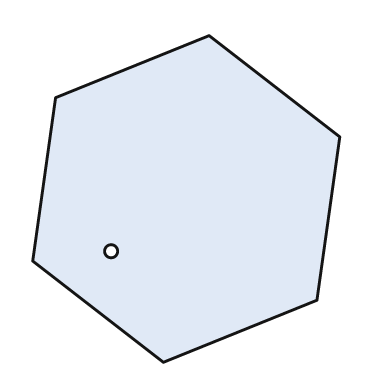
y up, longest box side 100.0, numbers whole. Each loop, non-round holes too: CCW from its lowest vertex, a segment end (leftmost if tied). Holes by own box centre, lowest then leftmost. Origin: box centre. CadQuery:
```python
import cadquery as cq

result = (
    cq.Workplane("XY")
    .moveTo(-7.0, -50.0)
    .lineTo(40.0, -31.0)
    .lineTo(47.0, 19.0)
    .lineTo(7.0, 50.0)
    .lineTo(-40.0, 31.0)
    .lineTo(-47.0, -19.0)
    .close()
    .moveTo(-23.0, -16.0)
    .circle(2.0)
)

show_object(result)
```